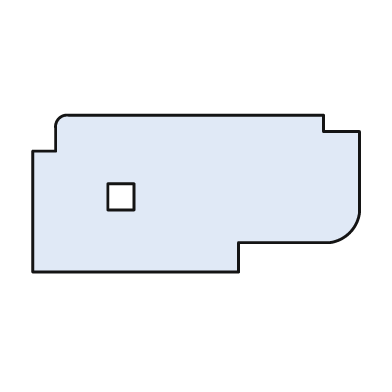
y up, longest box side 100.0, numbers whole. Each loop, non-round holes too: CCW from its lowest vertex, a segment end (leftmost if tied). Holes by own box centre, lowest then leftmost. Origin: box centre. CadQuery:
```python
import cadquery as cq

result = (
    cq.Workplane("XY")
    .moveTo(-50.0, -24.0)
    .lineTo(13.0, -24.0)
    .lineTo(13.0, -15.0)
    .lineTo(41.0, -15.0)
    .threePointArc((47.0, -12.0), (50.0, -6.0))
    .lineTo(50.0, 19.0)
    .lineTo(39.0, 19.0)
    .lineTo(39.0, 24.0)
    .lineTo(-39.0, 24.0)
    .threePointArc((-42.0, 23.0), (-43.0, 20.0))
    .lineTo(-43.0, 13.0)
    .lineTo(-50.0, 13.0)
    .close()
    .moveTo(-27.0, -5.0)
    .lineTo(-19.0, -5.0)
    .lineTo(-19.0, 3.0)
    .lineTo(-27.0, 3.0)
    .close()
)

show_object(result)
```